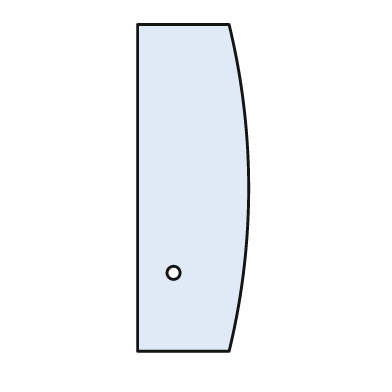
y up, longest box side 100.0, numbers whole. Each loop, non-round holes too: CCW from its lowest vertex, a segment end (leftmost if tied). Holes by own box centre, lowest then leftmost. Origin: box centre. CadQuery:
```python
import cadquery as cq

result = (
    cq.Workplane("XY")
    .moveTo(-17.0, -50.0)
    .lineTo(11.0, -50.0)
    .threePointArc((17.0, 0.0), (11.0, 50.0))
    .lineTo(-17.0, 50.0)
    .close()
    .moveTo(-6.0, -26.0)
    .circle(2.0)
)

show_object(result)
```